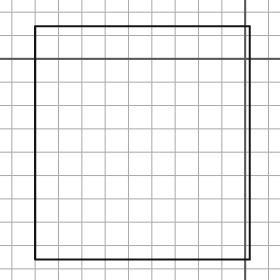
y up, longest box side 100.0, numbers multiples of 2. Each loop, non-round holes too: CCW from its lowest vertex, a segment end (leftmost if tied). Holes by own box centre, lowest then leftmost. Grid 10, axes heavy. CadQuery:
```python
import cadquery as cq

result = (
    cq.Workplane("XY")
    .moveTo(-90.0, -86.0)
    .lineTo(2.0, -86.0)
    .lineTo(2.0, 14.0)
    .lineTo(-90.0, 14.0)
    .close()
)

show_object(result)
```